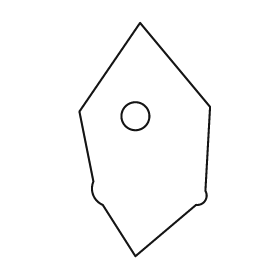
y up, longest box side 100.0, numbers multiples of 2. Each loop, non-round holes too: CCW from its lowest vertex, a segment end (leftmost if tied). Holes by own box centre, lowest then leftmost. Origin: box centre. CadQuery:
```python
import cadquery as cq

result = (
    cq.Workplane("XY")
    .moveTo(-4.0, -50.0)
    .lineTo(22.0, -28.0)
    .threePointArc((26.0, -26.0), (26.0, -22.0))
    .lineTo(28.0, 14.0)
    .lineTo(-2.0, 50.0)
    .lineTo(-28.0, 12.0)
    .lineTo(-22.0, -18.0)
    .threePointArc((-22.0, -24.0), (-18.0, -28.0))
    .close()
    .moveTo(-4.0, 10.0)
    .circle(6.0)
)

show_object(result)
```